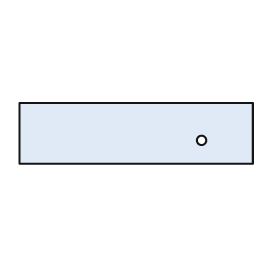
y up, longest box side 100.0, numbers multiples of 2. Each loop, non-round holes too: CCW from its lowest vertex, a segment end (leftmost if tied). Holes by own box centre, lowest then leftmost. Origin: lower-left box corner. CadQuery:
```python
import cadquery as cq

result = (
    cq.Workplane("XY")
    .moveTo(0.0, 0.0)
    .lineTo(100.0, 0.0)
    .lineTo(100.0, 26.0)
    .lineTo(0.0, 26.0)
    .close()
    .moveTo(78.0, 10.0)
    .circle(2.0)
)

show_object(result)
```